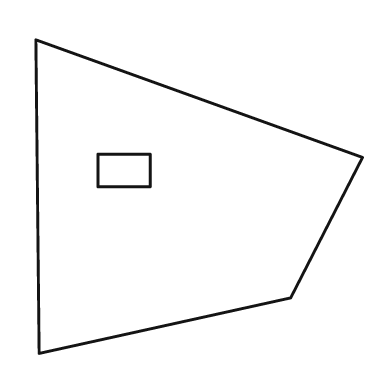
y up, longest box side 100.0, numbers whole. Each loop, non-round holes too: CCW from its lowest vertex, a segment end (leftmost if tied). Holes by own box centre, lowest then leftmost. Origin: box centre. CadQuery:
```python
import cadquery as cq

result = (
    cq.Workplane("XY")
    .moveTo(-49.0, -48.0)
    .lineTo(28.0, -31.0)
    .lineTo(50.0, 12.0)
    .lineTo(-50.0, 48.0)
    .close()
    .moveTo(-31.0, 3.0)
    .lineTo(-15.0, 3.0)
    .lineTo(-15.0, 13.0)
    .lineTo(-31.0, 13.0)
    .close()
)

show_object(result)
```